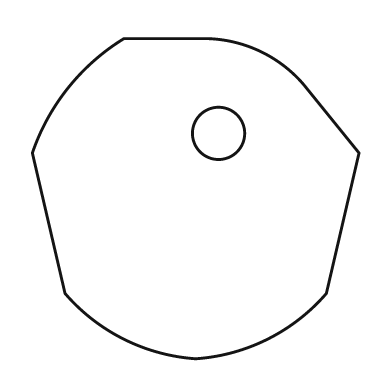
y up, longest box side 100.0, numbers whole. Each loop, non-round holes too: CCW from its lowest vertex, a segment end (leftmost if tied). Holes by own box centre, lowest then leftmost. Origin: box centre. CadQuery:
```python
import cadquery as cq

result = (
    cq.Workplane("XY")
    .moveTo(0.0, -49.0)
    .threePointArc((22.0, -43.0), (40.0, -29.0))
    .lineTo(50.0, 14.0)
    .lineTo(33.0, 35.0)
    .threePointArc((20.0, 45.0), (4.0, 49.0))
    .lineTo(-22.0, 49.0)
    .threePointArc((-39.0, 34.0), (-50.0, 14.0))
    .lineTo(-40.0, -29.0)
    .threePointArc((-22.0, -43.0), (0.0, -49.0))
    .close()
    .moveTo(7.0, 20.0)
    .circle(8.0)
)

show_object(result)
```